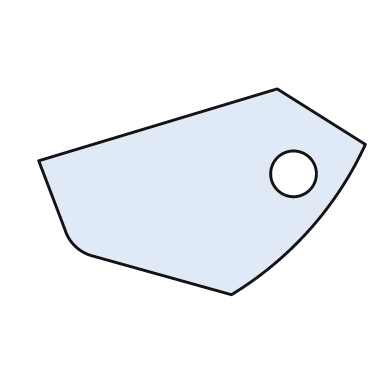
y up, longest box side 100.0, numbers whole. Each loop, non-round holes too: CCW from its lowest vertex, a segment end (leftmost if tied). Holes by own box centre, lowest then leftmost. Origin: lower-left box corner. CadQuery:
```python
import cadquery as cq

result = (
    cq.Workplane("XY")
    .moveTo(59.0, 0.0)
    .threePointArc((83.0, 20.0), (100.0, 46.0))
    .lineTo(73.0, 63.0)
    .lineTo(0.0, 41.0)
    .lineTo(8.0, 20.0)
    .threePointArc((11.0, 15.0), (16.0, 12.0))
    .close()
    .moveTo(78.0, 37.0)
    .circle(7.0)
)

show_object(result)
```